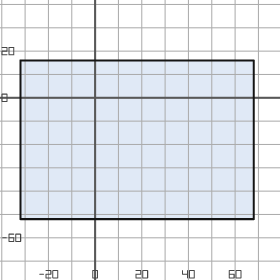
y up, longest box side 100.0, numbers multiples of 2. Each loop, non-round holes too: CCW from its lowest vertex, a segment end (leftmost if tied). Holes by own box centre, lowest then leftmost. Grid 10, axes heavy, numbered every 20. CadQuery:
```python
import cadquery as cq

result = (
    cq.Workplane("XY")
    .moveTo(-32.0, -52.0)
    .lineTo(68.0, -52.0)
    .lineTo(68.0, 16.0)
    .lineTo(-32.0, 16.0)
    .close()
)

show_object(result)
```